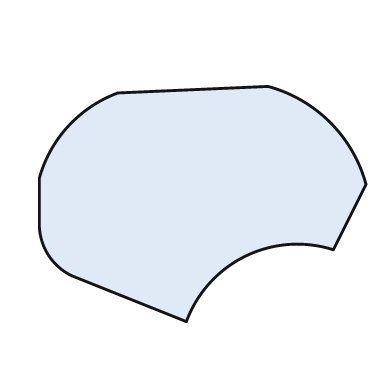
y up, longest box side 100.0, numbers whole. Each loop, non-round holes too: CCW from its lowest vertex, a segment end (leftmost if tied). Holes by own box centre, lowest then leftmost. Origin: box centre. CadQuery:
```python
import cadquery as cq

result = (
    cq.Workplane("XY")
    .moveTo(-5.0, -36.0)
    .threePointArc((13.0, -16.0), (40.0, -14.0))
    .lineTo(50.0, 6.0)
    .threePointArc((39.0, 25.0), (20.0, 36.0))
    .lineTo(-26.0, 34.0)
    .threePointArc((-41.0, 24.0), (-50.0, 8.0))
    .lineTo(-50.0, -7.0)
    .threePointArc((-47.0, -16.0), (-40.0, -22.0))
    .close()
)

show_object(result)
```